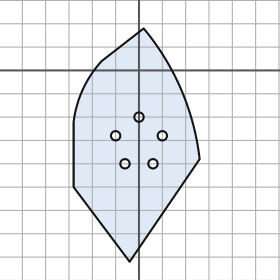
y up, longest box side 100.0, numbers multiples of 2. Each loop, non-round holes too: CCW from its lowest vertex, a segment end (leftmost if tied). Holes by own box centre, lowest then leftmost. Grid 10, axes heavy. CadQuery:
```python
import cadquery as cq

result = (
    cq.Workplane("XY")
    .moveTo(-4.0, -82.0)
    .lineTo(26.0, -38.0)
    .threePointArc((18.0, -8.0), (2.0, 18.0))
    .lineTo(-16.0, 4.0)
    .threePointArc((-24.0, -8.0), (-28.0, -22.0))
    .lineTo(-28.0, -50.0)
    .close()
    .moveTo(-6.0, -40.0)
    .circle(2.0)
    .moveTo(6.0, -40.0)
    .circle(2.0)
    .moveTo(-10.0, -28.0)
    .circle(2.0)
    .moveTo(10.0, -28.0)
    .circle(2.0)
    .moveTo(0.0, -20.0)
    .circle(2.0)
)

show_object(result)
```